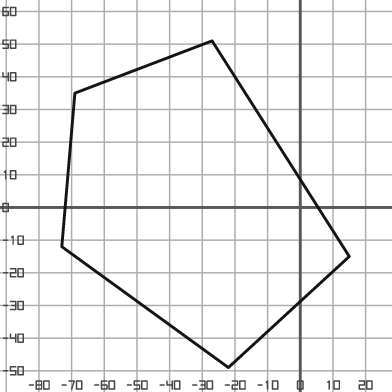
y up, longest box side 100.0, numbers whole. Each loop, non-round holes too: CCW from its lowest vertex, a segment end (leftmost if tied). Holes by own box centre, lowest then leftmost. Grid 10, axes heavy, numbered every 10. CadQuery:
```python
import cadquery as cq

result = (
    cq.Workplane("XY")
    .moveTo(-22.0, -49.0)
    .lineTo(15.0, -15.0)
    .lineTo(-27.0, 51.0)
    .lineTo(-69.0, 35.0)
    .lineTo(-73.0, -12.0)
    .close()
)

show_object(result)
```